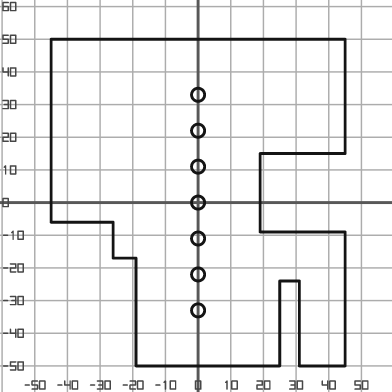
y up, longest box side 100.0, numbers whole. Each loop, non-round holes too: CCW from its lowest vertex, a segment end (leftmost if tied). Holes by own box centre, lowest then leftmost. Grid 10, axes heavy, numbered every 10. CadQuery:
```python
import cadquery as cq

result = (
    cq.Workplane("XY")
    .moveTo(-19.0, -50.0)
    .lineTo(25.0, -50.0)
    .lineTo(25.0, -24.0)
    .lineTo(31.0, -24.0)
    .lineTo(31.0, -50.0)
    .lineTo(45.0, -50.0)
    .lineTo(45.0, -9.0)
    .lineTo(19.0, -9.0)
    .lineTo(19.0, 15.0)
    .lineTo(45.0, 15.0)
    .lineTo(45.0, 50.0)
    .lineTo(-45.0, 50.0)
    .lineTo(-45.0, -6.0)
    .lineTo(-26.0, -6.0)
    .lineTo(-26.0, -17.0)
    .lineTo(-19.0, -17.0)
    .close()
    .moveTo(0.0, -33.0)
    .circle(2.0)
    .moveTo(0.0, -22.0)
    .circle(2.0)
    .moveTo(0.0, -11.0)
    .circle(2.0)
    .moveTo(0.0, 0.0)
    .circle(2.0)
    .moveTo(0.0, 11.0)
    .circle(2.0)
    .moveTo(0.0, 22.0)
    .circle(2.0)
    .moveTo(0.0, 33.0)
    .circle(2.0)
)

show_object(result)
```